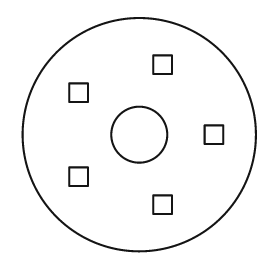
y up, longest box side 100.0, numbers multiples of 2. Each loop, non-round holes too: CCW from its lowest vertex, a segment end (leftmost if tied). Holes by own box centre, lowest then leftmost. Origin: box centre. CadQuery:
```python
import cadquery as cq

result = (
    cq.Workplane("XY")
    .moveTo(0.0, 0.0)
    .circle(50.0)
    .moveTo(6.0, -34.0)
    .lineTo(14.0, -34.0)
    .lineTo(14.0, -26.0)
    .lineTo(6.0, -26.0)
    .close()
    .moveTo(-30.0, -22.0)
    .lineTo(-22.0, -22.0)
    .lineTo(-22.0, -14.0)
    .lineTo(-30.0, -14.0)
    .close()
    .moveTo(0.0, 0.0)
    .circle(12.0)
    .moveTo(28.0, -4.0)
    .lineTo(36.0, -4.0)
    .lineTo(36.0, 4.0)
    .lineTo(28.0, 4.0)
    .close()
    .moveTo(-30.0, 14.0)
    .lineTo(-22.0, 14.0)
    .lineTo(-22.0, 22.0)
    .lineTo(-30.0, 22.0)
    .close()
    .moveTo(6.0, 26.0)
    .lineTo(14.0, 26.0)
    .lineTo(14.0, 34.0)
    .lineTo(6.0, 34.0)
    .close()
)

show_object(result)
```